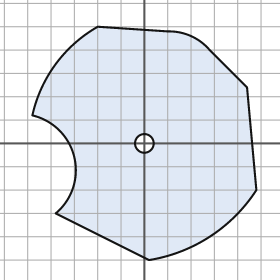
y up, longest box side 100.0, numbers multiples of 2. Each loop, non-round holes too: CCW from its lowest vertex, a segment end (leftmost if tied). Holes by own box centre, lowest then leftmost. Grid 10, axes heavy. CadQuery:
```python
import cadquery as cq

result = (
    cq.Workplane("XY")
    .moveTo(2.0, -50.0)
    .threePointArc((28.0, -40.0), (48.0, -20.0))
    .lineTo(44.0, 24.0)
    .lineTo(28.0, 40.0)
    .threePointArc((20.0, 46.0), (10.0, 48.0))
    .lineTo(-20.0, 50.0)
    .threePointArc((-38.0, 34.0), (-48.0, 12.0))
    .threePointArc((-30.0, -6.0), (-38.0, -30.0))
    .close()
    .moveTo(0.0, 0.0)
    .circle(4.0)
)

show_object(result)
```